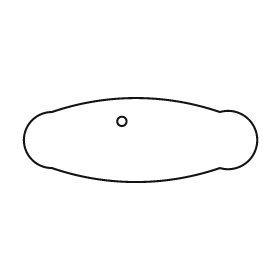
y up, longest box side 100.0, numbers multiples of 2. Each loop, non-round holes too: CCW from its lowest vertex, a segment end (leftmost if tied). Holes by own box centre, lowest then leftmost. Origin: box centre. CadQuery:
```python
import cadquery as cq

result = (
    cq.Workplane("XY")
    .moveTo(-38.0, -12.0)
    .threePointArc((-2.0, -18.0), (34.0, -12.0))
    .threePointArc((50.0, 0.0), (34.0, 12.0))
    .threePointArc((-2.0, 18.0), (-38.0, 12.0))
    .threePointArc((-50.0, 0.0), (-38.0, -12.0))
    .close()
    .moveTo(-8.0, 8.0)
    .circle(2.0)
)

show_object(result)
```